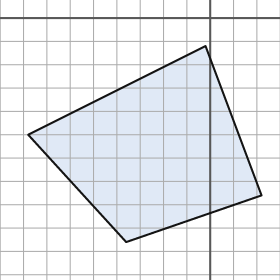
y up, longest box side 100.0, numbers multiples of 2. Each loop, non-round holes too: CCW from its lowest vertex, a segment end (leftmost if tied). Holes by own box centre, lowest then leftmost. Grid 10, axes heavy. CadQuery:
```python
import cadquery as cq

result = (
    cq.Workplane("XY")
    .moveTo(-36.0, -96.0)
    .lineTo(22.0, -76.0)
    .lineTo(-2.0, -12.0)
    .lineTo(-78.0, -50.0)
    .close()
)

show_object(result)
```